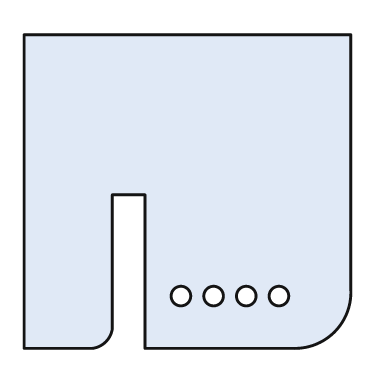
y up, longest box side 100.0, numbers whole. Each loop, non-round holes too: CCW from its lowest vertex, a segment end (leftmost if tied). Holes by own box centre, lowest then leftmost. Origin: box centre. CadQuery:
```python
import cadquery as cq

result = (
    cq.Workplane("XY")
    .moveTo(-50.0, -48.0)
    .lineTo(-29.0, -48.0)
    .threePointArc((-25.0, -46.0), (-23.0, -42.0))
    .lineTo(-23.0, -1.0)
    .lineTo(-13.0, -1.0)
    .lineTo(-13.0, -48.0)
    .lineTo(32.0, -48.0)
    .threePointArc((45.0, -43.0), (50.0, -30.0))
    .lineTo(50.0, 48.0)
    .lineTo(-50.0, 48.0)
    .close()
    .moveTo(-2.0, -32.0)
    .circle(3.0)
    .moveTo(8.0, -32.0)
    .circle(3.0)
    .moveTo(18.0, -32.0)
    .circle(3.0)
    .moveTo(28.0, -32.0)
    .circle(3.0)
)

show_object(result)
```